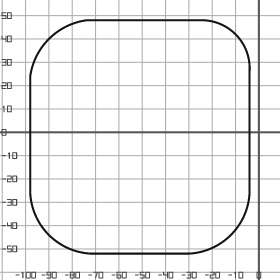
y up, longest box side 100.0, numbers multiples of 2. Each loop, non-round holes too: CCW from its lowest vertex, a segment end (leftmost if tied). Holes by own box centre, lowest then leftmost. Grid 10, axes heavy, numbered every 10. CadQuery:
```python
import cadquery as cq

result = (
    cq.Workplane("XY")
    .moveTo(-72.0, -52.0)
    .lineTo(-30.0, -52.0)
    .threePointArc((-12.0, -44.0), (-4.0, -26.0))
    .lineTo(-4.0, 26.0)
    .threePointArc((-10.0, 42.0), (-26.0, 48.0))
    .lineTo(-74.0, 48.0)
    .threePointArc((-90.0, 40.0), (-98.0, 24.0))
    .lineTo(-98.0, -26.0)
    .threePointArc((-90.0, -44.0), (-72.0, -52.0))
    .close()
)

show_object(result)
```